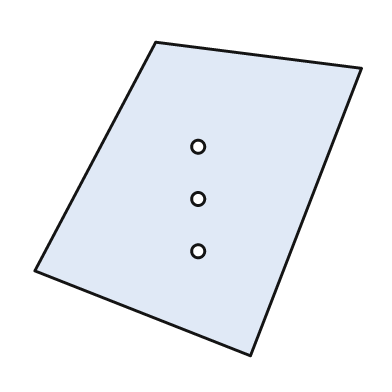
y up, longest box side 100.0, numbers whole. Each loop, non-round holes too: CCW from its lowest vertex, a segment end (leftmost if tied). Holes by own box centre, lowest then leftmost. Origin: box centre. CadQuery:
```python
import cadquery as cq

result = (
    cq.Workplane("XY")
    .moveTo(16.0, -48.0)
    .lineTo(50.0, 40.0)
    .lineTo(-13.0, 48.0)
    .lineTo(-50.0, -22.0)
    .close()
    .moveTo(0.0, -16.0)
    .circle(2.0)
    .moveTo(0.0, 0.0)
    .circle(2.0)
    .moveTo(0.0, 16.0)
    .circle(2.0)
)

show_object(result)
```